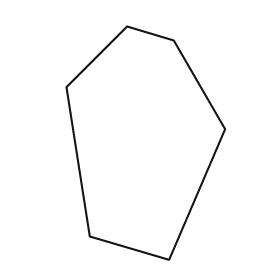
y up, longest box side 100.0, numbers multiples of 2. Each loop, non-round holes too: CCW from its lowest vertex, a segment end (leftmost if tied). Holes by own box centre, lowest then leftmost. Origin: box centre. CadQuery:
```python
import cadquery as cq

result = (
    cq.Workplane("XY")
    .moveTo(10.0, -50.0)
    .lineTo(34.0, 6.0)
    .lineTo(12.0, 44.0)
    .lineTo(-8.0, 50.0)
    .lineTo(-34.0, 24.0)
    .lineTo(-24.0, -40.0)
    .close()
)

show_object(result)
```